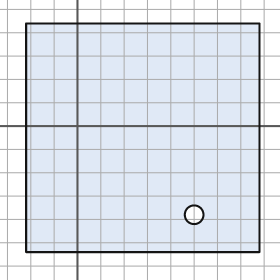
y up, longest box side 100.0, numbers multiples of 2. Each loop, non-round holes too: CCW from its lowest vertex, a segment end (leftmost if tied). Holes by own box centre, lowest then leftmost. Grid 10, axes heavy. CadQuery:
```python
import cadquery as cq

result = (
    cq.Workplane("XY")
    .moveTo(-22.0, -54.0)
    .lineTo(78.0, -54.0)
    .lineTo(78.0, 44.0)
    .lineTo(-22.0, 44.0)
    .close()
    .moveTo(50.0, -38.0)
    .circle(4.0)
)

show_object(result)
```